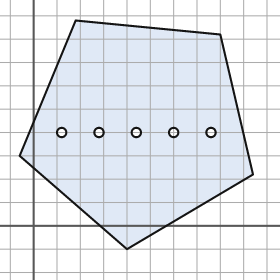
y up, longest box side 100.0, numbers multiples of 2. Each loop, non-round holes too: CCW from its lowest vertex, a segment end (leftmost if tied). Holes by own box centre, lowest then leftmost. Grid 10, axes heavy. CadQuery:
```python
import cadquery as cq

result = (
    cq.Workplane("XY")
    .moveTo(40.0, -10.0)
    .lineTo(94.0, 22.0)
    .lineTo(80.0, 82.0)
    .lineTo(18.0, 88.0)
    .lineTo(-6.0, 30.0)
    .close()
    .moveTo(12.0, 40.0)
    .circle(2.0)
    .moveTo(28.0, 40.0)
    .circle(2.0)
    .moveTo(44.0, 40.0)
    .circle(2.0)
    .moveTo(60.0, 40.0)
    .circle(2.0)
    .moveTo(76.0, 40.0)
    .circle(2.0)
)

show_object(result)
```